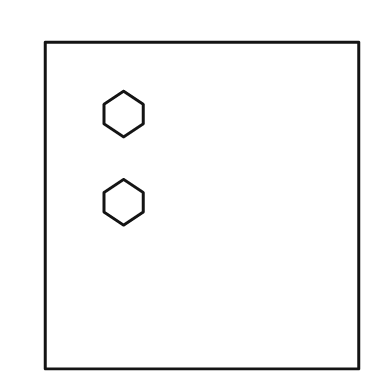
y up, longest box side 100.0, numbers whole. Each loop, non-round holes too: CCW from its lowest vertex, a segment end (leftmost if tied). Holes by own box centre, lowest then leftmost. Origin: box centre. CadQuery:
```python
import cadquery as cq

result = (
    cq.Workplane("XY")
    .moveTo(-48.0, -50.0)
    .lineTo(48.0, -50.0)
    .lineTo(48.0, 50.0)
    .lineTo(-48.0, 50.0)
    .close()
    .moveTo(-24.0, -6.0)
    .lineTo(-18.0, -2.0)
    .lineTo(-18.0, 4.0)
    .lineTo(-24.0, 8.0)
    .lineTo(-30.0, 4.0)
    .lineTo(-30.0, -2.0)
    .close()
    .moveTo(-24.0, 21.0)
    .lineTo(-18.0, 25.0)
    .lineTo(-18.0, 31.0)
    .lineTo(-24.0, 35.0)
    .lineTo(-30.0, 31.0)
    .lineTo(-30.0, 25.0)
    .close()
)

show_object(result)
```